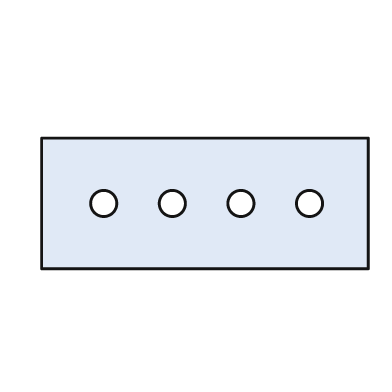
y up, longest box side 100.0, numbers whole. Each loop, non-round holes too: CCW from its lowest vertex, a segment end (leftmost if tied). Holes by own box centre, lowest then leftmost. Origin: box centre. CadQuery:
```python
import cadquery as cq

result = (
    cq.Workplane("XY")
    .moveTo(-50.0, -20.0)
    .lineTo(50.0, -20.0)
    .lineTo(50.0, 20.0)
    .lineTo(-50.0, 20.0)
    .close()
    .moveTo(-31.0, 0.0)
    .circle(4.0)
    .moveTo(-10.0, 0.0)
    .circle(4.0)
    .moveTo(11.0, 0.0)
    .circle(4.0)
    .moveTo(32.0, 0.0)
    .circle(4.0)
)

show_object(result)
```